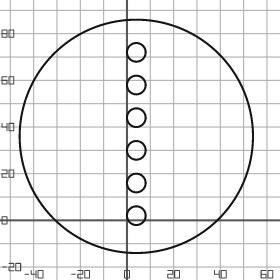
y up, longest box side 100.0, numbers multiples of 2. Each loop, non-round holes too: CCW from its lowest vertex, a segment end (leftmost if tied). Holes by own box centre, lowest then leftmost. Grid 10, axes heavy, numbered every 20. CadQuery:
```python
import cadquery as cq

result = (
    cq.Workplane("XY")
    .moveTo(4.0, 36.0)
    .circle(50.0)
    .moveTo(4.0, 2.0)
    .circle(4.0)
    .moveTo(4.0, 16.0)
    .circle(4.0)
    .moveTo(4.0, 30.0)
    .circle(4.0)
    .moveTo(4.0, 44.0)
    .circle(4.0)
    .moveTo(4.0, 58.0)
    .circle(4.0)
    .moveTo(4.0, 72.0)
    .circle(4.0)
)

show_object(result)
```